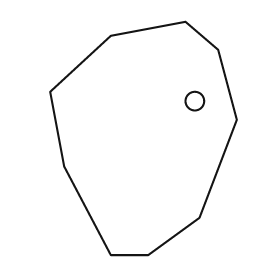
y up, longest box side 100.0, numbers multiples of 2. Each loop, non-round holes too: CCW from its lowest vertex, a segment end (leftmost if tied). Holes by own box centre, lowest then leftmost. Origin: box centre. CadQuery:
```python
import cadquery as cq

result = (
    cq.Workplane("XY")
    .moveTo(-14.0, -50.0)
    .lineTo(2.0, -50.0)
    .lineTo(24.0, -34.0)
    .lineTo(40.0, 8.0)
    .lineTo(32.0, 38.0)
    .lineTo(18.0, 50.0)
    .lineTo(-14.0, 44.0)
    .lineTo(-40.0, 20.0)
    .lineTo(-34.0, -12.0)
    .close()
    .moveTo(22.0, 16.0)
    .circle(4.0)
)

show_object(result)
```